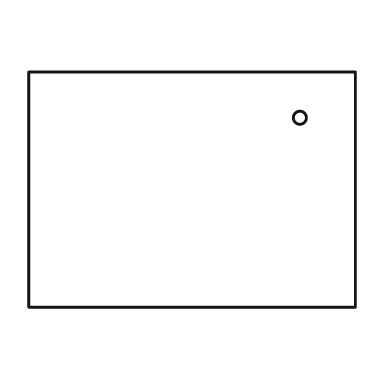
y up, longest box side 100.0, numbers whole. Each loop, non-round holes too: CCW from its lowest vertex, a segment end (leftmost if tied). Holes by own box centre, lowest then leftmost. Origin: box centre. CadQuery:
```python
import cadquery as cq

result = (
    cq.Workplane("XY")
    .moveTo(-50.0, -36.0)
    .lineTo(50.0, -36.0)
    .lineTo(50.0, 36.0)
    .lineTo(-50.0, 36.0)
    .close()
    .moveTo(33.0, 22.0)
    .circle(2.0)
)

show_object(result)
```